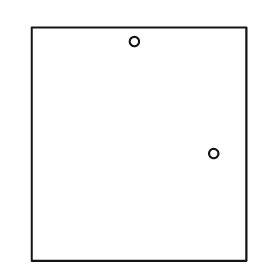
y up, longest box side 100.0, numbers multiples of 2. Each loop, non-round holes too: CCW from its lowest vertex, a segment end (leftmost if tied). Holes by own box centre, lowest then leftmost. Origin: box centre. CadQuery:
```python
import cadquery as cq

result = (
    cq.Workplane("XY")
    .moveTo(-46.0, -50.0)
    .lineTo(46.0, -50.0)
    .lineTo(46.0, 50.0)
    .lineTo(-46.0, 50.0)
    .close()
    .moveTo(32.0, -4.0)
    .circle(2.0)
    .moveTo(-2.0, 44.0)
    .circle(2.0)
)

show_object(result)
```